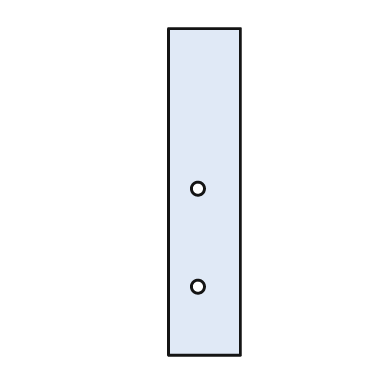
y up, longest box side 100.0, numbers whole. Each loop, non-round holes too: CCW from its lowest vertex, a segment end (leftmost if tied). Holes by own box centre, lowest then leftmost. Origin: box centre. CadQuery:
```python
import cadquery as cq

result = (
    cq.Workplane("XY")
    .moveTo(-11.0, -50.0)
    .lineTo(11.0, -50.0)
    .lineTo(11.0, 50.0)
    .lineTo(-11.0, 50.0)
    .close()
    .moveTo(-2.0, -29.0)
    .circle(2.0)
    .moveTo(-2.0, 1.0)
    .circle(2.0)
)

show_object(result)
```